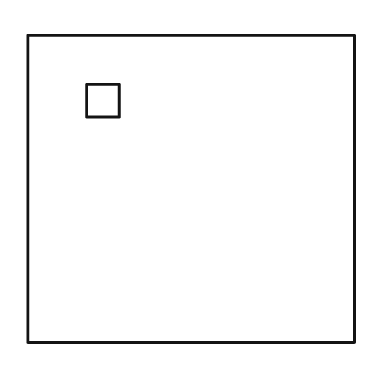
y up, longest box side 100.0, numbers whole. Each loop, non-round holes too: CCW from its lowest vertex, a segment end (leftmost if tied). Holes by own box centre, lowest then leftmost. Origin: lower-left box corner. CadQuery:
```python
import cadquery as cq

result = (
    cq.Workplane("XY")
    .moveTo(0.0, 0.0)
    .lineTo(100.0, 0.0)
    .lineTo(100.0, 94.0)
    .lineTo(0.0, 94.0)
    .close()
    .moveTo(18.0, 69.0)
    .lineTo(28.0, 69.0)
    .lineTo(28.0, 79.0)
    .lineTo(18.0, 79.0)
    .close()
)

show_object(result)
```